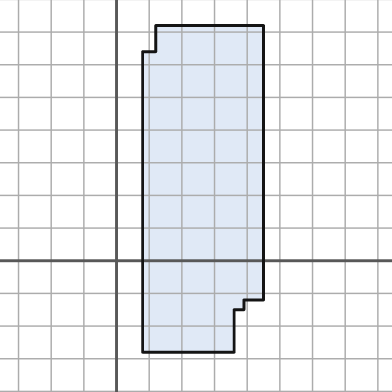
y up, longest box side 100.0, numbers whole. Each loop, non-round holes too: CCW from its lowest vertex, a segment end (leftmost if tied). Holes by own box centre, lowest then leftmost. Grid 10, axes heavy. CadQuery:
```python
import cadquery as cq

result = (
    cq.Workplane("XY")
    .moveTo(8.0, -28.0)
    .lineTo(36.0, -28.0)
    .lineTo(36.0, -15.0)
    .lineTo(39.0, -15.0)
    .lineTo(39.0, -12.0)
    .lineTo(45.0, -12.0)
    .lineTo(45.0, 72.0)
    .lineTo(12.0, 72.0)
    .lineTo(12.0, 64.0)
    .lineTo(8.0, 64.0)
    .close()
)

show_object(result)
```